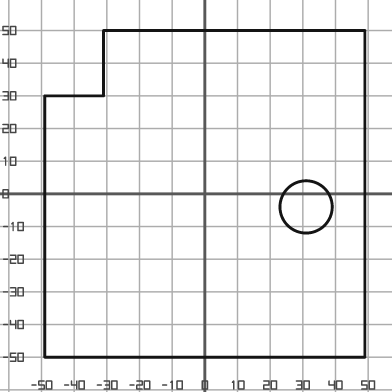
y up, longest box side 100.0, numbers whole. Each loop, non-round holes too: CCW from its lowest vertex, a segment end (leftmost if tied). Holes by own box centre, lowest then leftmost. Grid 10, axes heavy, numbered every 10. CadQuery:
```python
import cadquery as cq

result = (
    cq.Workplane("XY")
    .moveTo(-49.0, -50.0)
    .lineTo(49.0, -50.0)
    .lineTo(49.0, 50.0)
    .lineTo(-31.0, 50.0)
    .lineTo(-31.0, 30.0)
    .lineTo(-49.0, 30.0)
    .close()
    .moveTo(31.0, -4.0)
    .circle(8.0)
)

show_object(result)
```